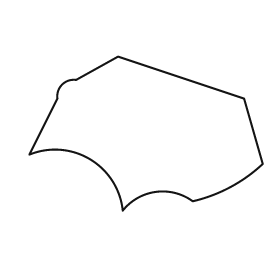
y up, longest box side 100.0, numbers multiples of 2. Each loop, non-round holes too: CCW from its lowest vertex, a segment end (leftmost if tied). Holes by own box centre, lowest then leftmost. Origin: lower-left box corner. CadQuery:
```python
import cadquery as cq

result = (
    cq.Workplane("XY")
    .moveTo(40.0, 0.0)
    .threePointArc((54.0, 8.0), (70.0, 4.0))
    .threePointArc((86.0, 10.0), (100.0, 20.0))
    .lineTo(92.0, 48.0)
    .lineTo(38.0, 66.0)
    .lineTo(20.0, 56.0)
    .threePointArc((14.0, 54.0), (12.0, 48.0))
    .lineTo(0.0, 24.0)
    .threePointArc((26.0, 22.0), (40.0, 0.0))
    .close()
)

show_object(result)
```